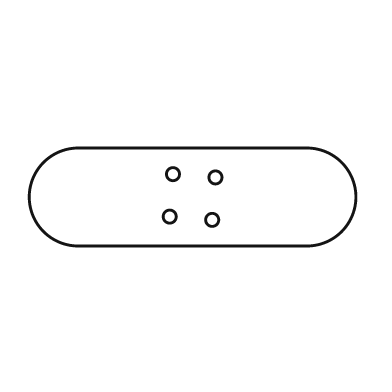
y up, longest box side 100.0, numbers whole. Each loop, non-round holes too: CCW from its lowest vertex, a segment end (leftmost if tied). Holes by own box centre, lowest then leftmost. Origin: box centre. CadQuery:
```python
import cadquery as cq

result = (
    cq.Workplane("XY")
    .moveTo(-35.0, -15.0)
    .lineTo(35.0, -15.0)
    .threePointArc((50.0, 0.0), (35.0, 15.0))
    .lineTo(-35.0, 15.0)
    .threePointArc((-50.0, 0.0), (-35.0, -15.0))
    .close()
    .moveTo(6.0, -7.0)
    .circle(2.0)
    .moveTo(-7.0, -6.0)
    .circle(2.0)
    .moveTo(7.0, 6.0)
    .circle(2.0)
    .moveTo(-6.0, 7.0)
    .circle(2.0)
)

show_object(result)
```